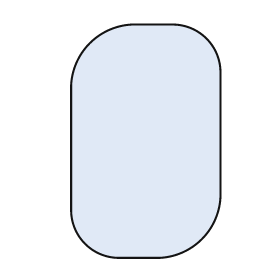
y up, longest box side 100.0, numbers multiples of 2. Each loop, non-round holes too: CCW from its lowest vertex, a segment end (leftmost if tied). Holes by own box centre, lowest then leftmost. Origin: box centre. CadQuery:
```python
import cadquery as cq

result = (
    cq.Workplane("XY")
    .moveTo(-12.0, -50.0)
    .lineTo(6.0, -50.0)
    .threePointArc((24.0, -42.0), (32.0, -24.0))
    .lineTo(32.0, 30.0)
    .threePointArc((26.0, 44.0), (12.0, 50.0))
    .lineTo(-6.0, 50.0)
    .threePointArc((-24.0, 42.0), (-32.0, 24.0))
    .lineTo(-32.0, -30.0)
    .threePointArc((-26.0, -44.0), (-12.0, -50.0))
    .close()
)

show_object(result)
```